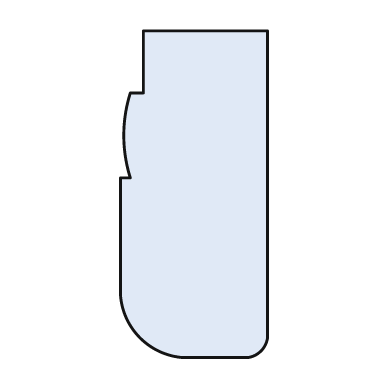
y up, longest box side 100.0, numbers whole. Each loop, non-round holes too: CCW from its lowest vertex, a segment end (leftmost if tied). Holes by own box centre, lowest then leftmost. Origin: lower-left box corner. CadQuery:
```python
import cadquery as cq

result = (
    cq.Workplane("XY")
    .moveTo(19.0, 0.0)
    .lineTo(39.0, 0.0)
    .threePointArc((43.0, 2.0), (45.0, 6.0))
    .lineTo(45.0, 100.0)
    .lineTo(7.0, 100.0)
    .lineTo(7.0, 81.0)
    .lineTo(3.0, 81.0)
    .threePointArc((1.0, 68.0), (3.0, 55.0))
    .lineTo(0.0, 55.0)
    .lineTo(0.0, 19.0)
    .threePointArc((6.0, 6.0), (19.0, 0.0))
    .close()
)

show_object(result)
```